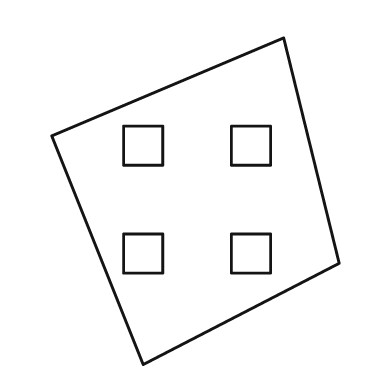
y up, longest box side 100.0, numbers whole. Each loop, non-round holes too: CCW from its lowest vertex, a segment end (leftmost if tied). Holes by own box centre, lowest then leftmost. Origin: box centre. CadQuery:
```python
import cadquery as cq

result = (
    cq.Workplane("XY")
    .moveTo(-16.0, -50.0)
    .lineTo(44.0, -19.0)
    .lineTo(27.0, 50.0)
    .lineTo(-44.0, 20.0)
    .close()
    .moveTo(-22.0, -22.0)
    .lineTo(-10.0, -22.0)
    .lineTo(-10.0, -10.0)
    .lineTo(-22.0, -10.0)
    .close()
    .moveTo(11.0, -22.0)
    .lineTo(23.0, -22.0)
    .lineTo(23.0, -10.0)
    .lineTo(11.0, -10.0)
    .close()
    .moveTo(-22.0, 11.0)
    .lineTo(-10.0, 11.0)
    .lineTo(-10.0, 23.0)
    .lineTo(-22.0, 23.0)
    .close()
    .moveTo(11.0, 11.0)
    .lineTo(23.0, 11.0)
    .lineTo(23.0, 23.0)
    .lineTo(11.0, 23.0)
    .close()
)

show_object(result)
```